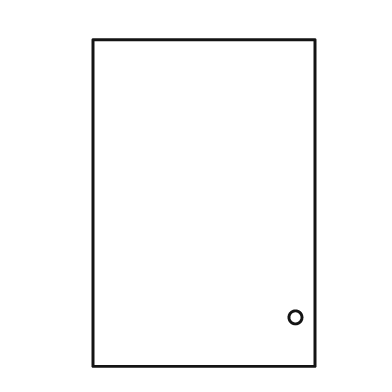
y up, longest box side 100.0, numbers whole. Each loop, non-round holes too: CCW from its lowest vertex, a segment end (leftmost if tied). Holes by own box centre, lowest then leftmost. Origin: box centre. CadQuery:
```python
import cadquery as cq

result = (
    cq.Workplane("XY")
    .moveTo(-34.0, -50.0)
    .lineTo(34.0, -50.0)
    .lineTo(34.0, 50.0)
    .lineTo(-34.0, 50.0)
    .close()
    .moveTo(28.0, -35.0)
    .circle(2.0)
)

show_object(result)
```